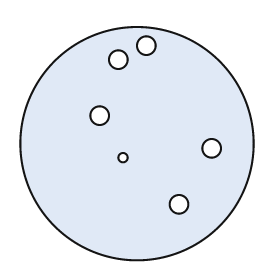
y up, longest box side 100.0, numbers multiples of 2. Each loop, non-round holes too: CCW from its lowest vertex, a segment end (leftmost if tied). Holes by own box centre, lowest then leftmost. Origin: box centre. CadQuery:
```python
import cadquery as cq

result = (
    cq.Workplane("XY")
    .moveTo(0.0, 0.0)
    .circle(50.0)
    .moveTo(18.0, -26.0)
    .circle(4.0)
    .moveTo(-6.0, -6.0)
    .circle(2.0)
    .moveTo(32.0, -2.0)
    .circle(4.0)
    .moveTo(-16.0, 12.0)
    .circle(4.0)
    .moveTo(-8.0, 36.0)
    .circle(4.0)
    .moveTo(4.0, 42.0)
    .circle(4.0)
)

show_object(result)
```